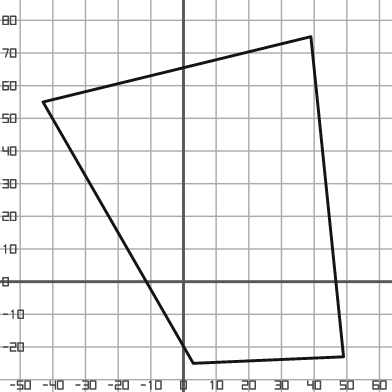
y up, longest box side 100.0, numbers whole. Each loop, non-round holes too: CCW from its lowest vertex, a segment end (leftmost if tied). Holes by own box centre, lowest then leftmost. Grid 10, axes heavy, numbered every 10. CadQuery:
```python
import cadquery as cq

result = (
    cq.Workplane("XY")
    .moveTo(3.0, -25.0)
    .lineTo(49.0, -23.0)
    .lineTo(39.0, 75.0)
    .lineTo(-43.0, 55.0)
    .close()
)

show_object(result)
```